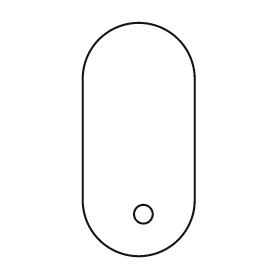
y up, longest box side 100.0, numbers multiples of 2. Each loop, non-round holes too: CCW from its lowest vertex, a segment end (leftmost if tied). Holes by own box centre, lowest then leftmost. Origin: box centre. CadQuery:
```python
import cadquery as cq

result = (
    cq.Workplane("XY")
    .moveTo(-24.0, -26.0)
    .threePointArc((0.0, -50.0), (24.0, -26.0))
    .lineTo(24.0, 26.0)
    .threePointArc((0.0, 50.0), (-24.0, 26.0))
    .close()
    .moveTo(2.0, -32.0)
    .circle(4.0)
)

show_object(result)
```